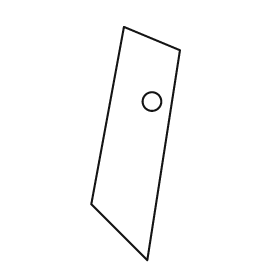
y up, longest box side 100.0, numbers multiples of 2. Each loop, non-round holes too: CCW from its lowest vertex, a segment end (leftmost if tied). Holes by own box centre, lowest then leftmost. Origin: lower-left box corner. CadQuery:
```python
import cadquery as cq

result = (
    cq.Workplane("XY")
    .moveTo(24.0, 0.0)
    .lineTo(38.0, 90.0)
    .lineTo(14.0, 100.0)
    .lineTo(0.0, 24.0)
    .close()
    .moveTo(26.0, 68.0)
    .circle(4.0)
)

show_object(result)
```